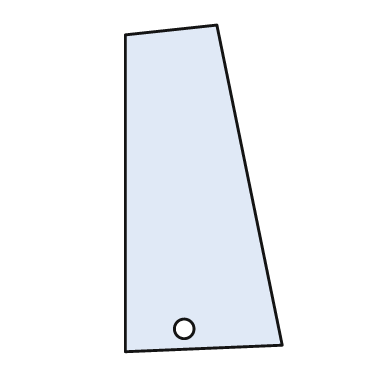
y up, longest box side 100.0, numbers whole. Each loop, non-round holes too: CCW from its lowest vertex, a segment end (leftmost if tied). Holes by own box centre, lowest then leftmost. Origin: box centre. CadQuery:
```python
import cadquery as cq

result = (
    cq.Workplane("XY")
    .moveTo(-24.0, -50.0)
    .lineTo(24.0, -48.0)
    .lineTo(4.0, 50.0)
    .lineTo(-24.0, 47.0)
    .close()
    .moveTo(-6.0, -43.0)
    .circle(3.0)
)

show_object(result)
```